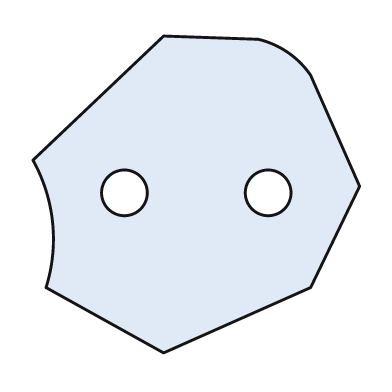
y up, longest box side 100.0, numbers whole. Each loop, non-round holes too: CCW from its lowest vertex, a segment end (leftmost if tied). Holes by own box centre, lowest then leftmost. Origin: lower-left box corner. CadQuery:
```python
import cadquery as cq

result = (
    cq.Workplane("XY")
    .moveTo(40.0, 0.0)
    .lineTo(85.0, 20.0)
    .lineTo(100.0, 51.0)
    .lineTo(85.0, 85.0)
    .threePointArc((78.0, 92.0), (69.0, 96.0))
    .lineTo(40.0, 97.0)
    .lineTo(0.0, 59.0)
    .threePointArc((6.0, 40.0), (4.0, 20.0))
    .close()
    .moveTo(28.0, 49.0)
    .circle(7.0)
    .moveTo(72.0, 49.0)
    .circle(7.0)
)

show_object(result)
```